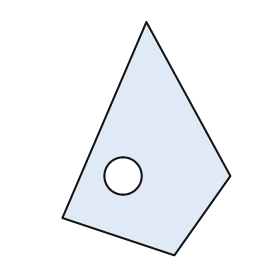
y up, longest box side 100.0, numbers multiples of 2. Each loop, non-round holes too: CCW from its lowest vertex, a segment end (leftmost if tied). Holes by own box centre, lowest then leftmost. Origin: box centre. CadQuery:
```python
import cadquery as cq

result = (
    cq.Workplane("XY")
    .moveTo(12.0, -50.0)
    .lineTo(36.0, -16.0)
    .lineTo(0.0, 50.0)
    .lineTo(-36.0, -34.0)
    .close()
    .moveTo(-10.0, -16.0)
    .circle(8.0)
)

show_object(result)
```